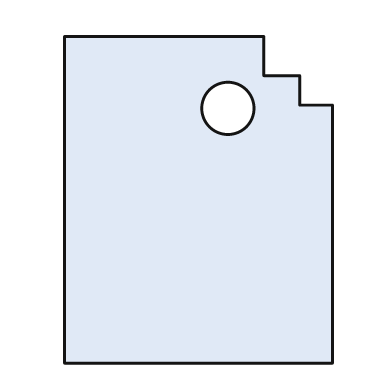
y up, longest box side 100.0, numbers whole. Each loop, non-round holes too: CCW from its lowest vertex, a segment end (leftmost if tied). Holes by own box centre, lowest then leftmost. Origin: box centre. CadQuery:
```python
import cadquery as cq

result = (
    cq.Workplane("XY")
    .moveTo(-41.0, -50.0)
    .lineTo(41.0, -50.0)
    .lineTo(41.0, 29.0)
    .lineTo(31.0, 29.0)
    .lineTo(31.0, 38.0)
    .lineTo(20.0, 38.0)
    .lineTo(20.0, 50.0)
    .lineTo(-41.0, 50.0)
    .close()
    .moveTo(9.0, 28.0)
    .circle(8.0)
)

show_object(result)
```